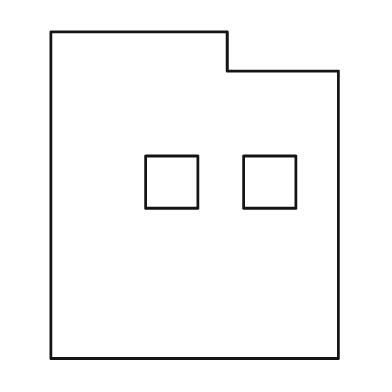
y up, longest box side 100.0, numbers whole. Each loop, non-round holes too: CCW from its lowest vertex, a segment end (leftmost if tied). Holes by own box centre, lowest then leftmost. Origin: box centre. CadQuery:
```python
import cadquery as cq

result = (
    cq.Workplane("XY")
    .moveTo(-44.0, -50.0)
    .lineTo(44.0, -50.0)
    .lineTo(44.0, 38.0)
    .lineTo(10.0, 38.0)
    .lineTo(10.0, 50.0)
    .lineTo(-44.0, 50.0)
    .close()
    .moveTo(-15.0, -4.0)
    .lineTo(1.0, -4.0)
    .lineTo(1.0, 12.0)
    .lineTo(-15.0, 12.0)
    .close()
    .moveTo(15.0, -4.0)
    .lineTo(31.0, -4.0)
    .lineTo(31.0, 12.0)
    .lineTo(15.0, 12.0)
    .close()
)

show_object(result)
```